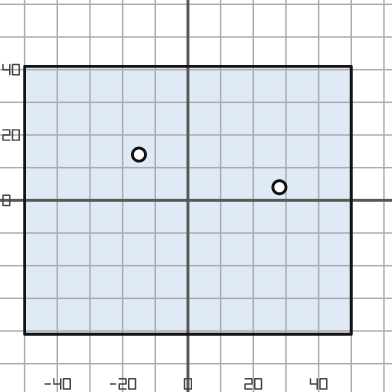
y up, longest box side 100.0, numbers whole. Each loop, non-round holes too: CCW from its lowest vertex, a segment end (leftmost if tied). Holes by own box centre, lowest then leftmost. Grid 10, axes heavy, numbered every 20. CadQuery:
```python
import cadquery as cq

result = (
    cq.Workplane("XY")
    .moveTo(-50.0, -41.0)
    .lineTo(50.0, -41.0)
    .lineTo(50.0, 41.0)
    .lineTo(-50.0, 41.0)
    .close()
    .moveTo(28.0, 4.0)
    .circle(2.0)
    .moveTo(-15.0, 14.0)
    .circle(2.0)
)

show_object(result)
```